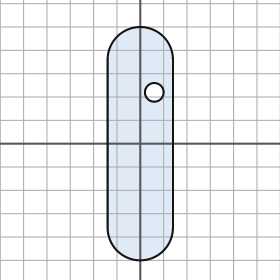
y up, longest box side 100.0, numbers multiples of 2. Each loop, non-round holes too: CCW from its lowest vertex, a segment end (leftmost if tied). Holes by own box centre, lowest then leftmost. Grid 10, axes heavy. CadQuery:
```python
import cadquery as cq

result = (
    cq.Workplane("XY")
    .moveTo(-14.0, -36.0)
    .threePointArc((0.0, -50.0), (14.0, -36.0))
    .lineTo(14.0, 36.0)
    .threePointArc((0.0, 50.0), (-14.0, 36.0))
    .close()
    .moveTo(6.0, 22.0)
    .circle(4.0)
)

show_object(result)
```